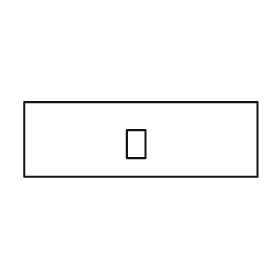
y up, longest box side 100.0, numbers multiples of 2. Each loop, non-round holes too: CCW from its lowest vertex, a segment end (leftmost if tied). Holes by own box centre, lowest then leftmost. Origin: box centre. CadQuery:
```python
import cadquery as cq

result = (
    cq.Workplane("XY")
    .moveTo(-50.0, -16.0)
    .lineTo(50.0, -16.0)
    .lineTo(50.0, 16.0)
    .lineTo(-50.0, 16.0)
    .close()
    .moveTo(-6.0, -8.0)
    .lineTo(2.0, -8.0)
    .lineTo(2.0, 4.0)
    .lineTo(-6.0, 4.0)
    .close()
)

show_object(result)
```